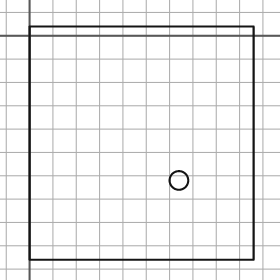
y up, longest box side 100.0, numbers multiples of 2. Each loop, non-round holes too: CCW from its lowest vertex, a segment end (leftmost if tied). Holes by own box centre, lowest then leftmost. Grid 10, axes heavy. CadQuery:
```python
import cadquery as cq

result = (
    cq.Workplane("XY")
    .moveTo(0.0, -96.0)
    .lineTo(96.0, -96.0)
    .lineTo(96.0, 4.0)
    .lineTo(0.0, 4.0)
    .close()
    .moveTo(64.0, -62.0)
    .circle(4.0)
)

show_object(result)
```